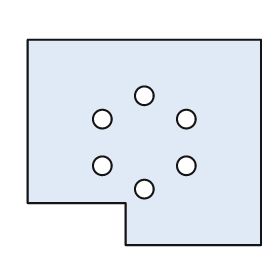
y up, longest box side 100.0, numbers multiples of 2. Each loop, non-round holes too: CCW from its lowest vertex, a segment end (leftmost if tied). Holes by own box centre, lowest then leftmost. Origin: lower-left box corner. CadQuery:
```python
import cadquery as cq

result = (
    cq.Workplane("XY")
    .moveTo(42.0, 0.0)
    .lineTo(100.0, 0.0)
    .lineTo(100.0, 88.0)
    .lineTo(0.0, 88.0)
    .lineTo(0.0, 18.0)
    .lineTo(42.0, 18.0)
    .close()
    .moveTo(50.0, 24.0)
    .circle(4.0)
    .moveTo(32.0, 34.0)
    .circle(4.0)
    .moveTo(68.0, 34.0)
    .circle(4.0)
    .moveTo(32.0, 54.0)
    .circle(4.0)
    .moveTo(68.0, 54.0)
    .circle(4.0)
    .moveTo(50.0, 64.0)
    .circle(4.0)
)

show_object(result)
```